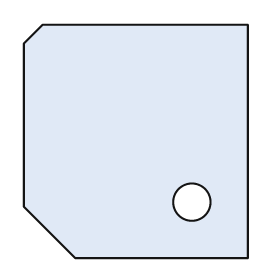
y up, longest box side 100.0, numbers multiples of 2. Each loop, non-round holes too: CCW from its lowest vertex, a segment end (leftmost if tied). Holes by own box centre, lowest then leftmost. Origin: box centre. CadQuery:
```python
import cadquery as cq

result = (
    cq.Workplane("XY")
    .moveTo(-26.0, -50.0)
    .lineTo(48.0, -50.0)
    .lineTo(48.0, 50.0)
    .lineTo(-40.0, 50.0)
    .lineTo(-48.0, 42.0)
    .lineTo(-48.0, -28.0)
    .close()
    .moveTo(24.0, -26.0)
    .circle(8.0)
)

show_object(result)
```